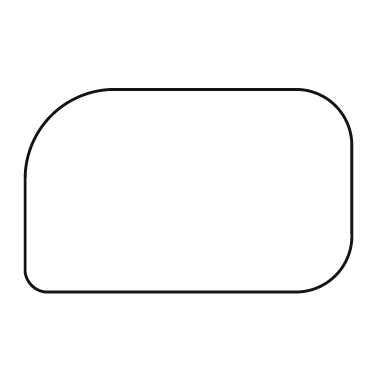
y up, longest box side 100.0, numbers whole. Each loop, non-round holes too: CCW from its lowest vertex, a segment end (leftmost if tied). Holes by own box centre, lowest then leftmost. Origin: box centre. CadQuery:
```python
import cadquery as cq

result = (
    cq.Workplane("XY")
    .moveTo(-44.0, -31.0)
    .lineTo(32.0, -31.0)
    .threePointArc((45.0, -26.0), (50.0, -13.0))
    .lineTo(50.0, 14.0)
    .threePointArc((45.0, 26.0), (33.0, 31.0))
    .lineTo(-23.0, 31.0)
    .threePointArc((-42.0, 23.0), (-50.0, 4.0))
    .lineTo(-50.0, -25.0)
    .threePointArc((-48.0, -29.0), (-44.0, -31.0))
    .close()
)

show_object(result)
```